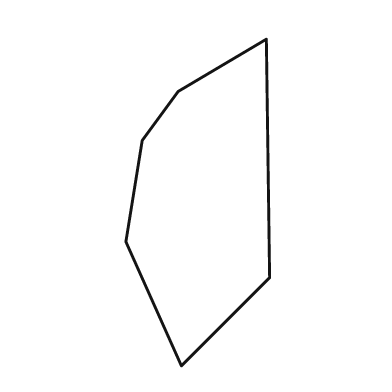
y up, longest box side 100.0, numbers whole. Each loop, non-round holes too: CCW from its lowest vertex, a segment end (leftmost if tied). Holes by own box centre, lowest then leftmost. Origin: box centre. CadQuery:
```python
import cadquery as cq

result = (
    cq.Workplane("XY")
    .moveTo(-5.0, -50.0)
    .lineTo(22.0, -23.0)
    .lineTo(21.0, 50.0)
    .lineTo(-6.0, 34.0)
    .lineTo(-17.0, 19.0)
    .lineTo(-22.0, -12.0)
    .close()
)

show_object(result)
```